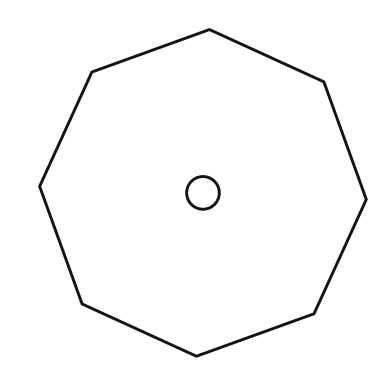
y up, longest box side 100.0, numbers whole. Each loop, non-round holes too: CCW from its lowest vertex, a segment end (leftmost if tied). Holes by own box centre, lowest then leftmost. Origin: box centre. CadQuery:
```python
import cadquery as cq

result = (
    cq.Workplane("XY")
    .moveTo(-2.0, -50.0)
    .lineTo(34.0, -37.0)
    .lineTo(50.0, -2.0)
    .lineTo(37.0, 34.0)
    .lineTo(2.0, 50.0)
    .lineTo(-34.0, 37.0)
    .lineTo(-50.0, 2.0)
    .lineTo(-37.0, -34.0)
    .close()
    .moveTo(0.0, 0.0)
    .circle(5.0)
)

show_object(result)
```